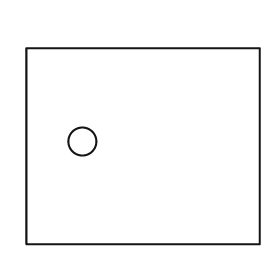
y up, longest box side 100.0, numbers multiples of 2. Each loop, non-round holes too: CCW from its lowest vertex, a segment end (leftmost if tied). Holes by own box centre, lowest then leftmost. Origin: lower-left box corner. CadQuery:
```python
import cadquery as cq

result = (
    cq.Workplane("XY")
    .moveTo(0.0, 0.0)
    .lineTo(100.0, 0.0)
    .lineTo(100.0, 84.0)
    .lineTo(0.0, 84.0)
    .close()
    .moveTo(24.0, 44.0)
    .circle(6.0)
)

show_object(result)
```